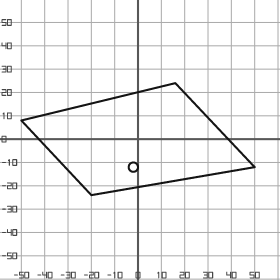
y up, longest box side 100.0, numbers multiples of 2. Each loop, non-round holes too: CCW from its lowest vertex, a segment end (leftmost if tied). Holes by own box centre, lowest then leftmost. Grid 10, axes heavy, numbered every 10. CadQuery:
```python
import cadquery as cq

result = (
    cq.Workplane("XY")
    .moveTo(-20.0, -24.0)
    .lineTo(50.0, -12.0)
    .lineTo(16.0, 24.0)
    .lineTo(-50.0, 8.0)
    .close()
    .moveTo(-2.0, -12.0)
    .circle(2.0)
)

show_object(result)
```